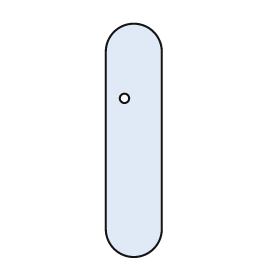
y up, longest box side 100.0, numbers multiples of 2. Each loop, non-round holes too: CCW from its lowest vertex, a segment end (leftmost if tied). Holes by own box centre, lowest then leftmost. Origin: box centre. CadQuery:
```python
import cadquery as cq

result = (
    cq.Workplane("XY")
    .moveTo(-12.0, -38.0)
    .threePointArc((0.0, -50.0), (12.0, -38.0))
    .lineTo(12.0, 38.0)
    .threePointArc((0.0, 50.0), (-12.0, 38.0))
    .close()
    .moveTo(-4.0, 18.0)
    .circle(2.0)
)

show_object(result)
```